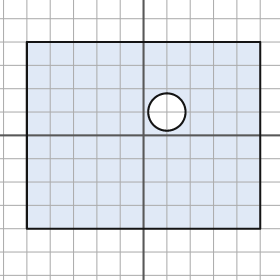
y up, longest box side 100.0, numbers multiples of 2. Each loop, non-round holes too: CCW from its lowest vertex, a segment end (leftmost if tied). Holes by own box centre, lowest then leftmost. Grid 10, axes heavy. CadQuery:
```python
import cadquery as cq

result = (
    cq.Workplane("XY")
    .moveTo(-50.0, -40.0)
    .lineTo(50.0, -40.0)
    .lineTo(50.0, 40.0)
    .lineTo(-50.0, 40.0)
    .close()
    .moveTo(10.0, 10.0)
    .circle(8.0)
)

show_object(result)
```